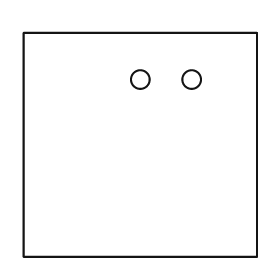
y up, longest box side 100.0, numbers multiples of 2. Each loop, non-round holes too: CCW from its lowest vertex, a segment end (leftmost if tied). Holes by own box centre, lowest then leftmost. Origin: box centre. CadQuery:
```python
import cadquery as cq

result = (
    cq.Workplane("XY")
    .moveTo(-50.0, -48.0)
    .lineTo(50.0, -48.0)
    .lineTo(50.0, 48.0)
    .lineTo(-50.0, 48.0)
    .close()
    .moveTo(0.0, 28.0)
    .circle(4.0)
    .moveTo(22.0, 28.0)
    .circle(4.0)
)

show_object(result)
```